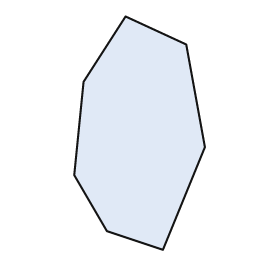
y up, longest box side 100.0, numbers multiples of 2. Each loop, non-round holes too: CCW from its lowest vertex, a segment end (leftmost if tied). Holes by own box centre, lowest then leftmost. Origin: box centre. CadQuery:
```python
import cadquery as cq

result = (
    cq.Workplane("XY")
    .moveTo(10.0, -50.0)
    .lineTo(28.0, -6.0)
    .lineTo(20.0, 38.0)
    .lineTo(-6.0, 50.0)
    .lineTo(-24.0, 22.0)
    .lineTo(-28.0, -18.0)
    .lineTo(-14.0, -42.0)
    .close()
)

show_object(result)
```